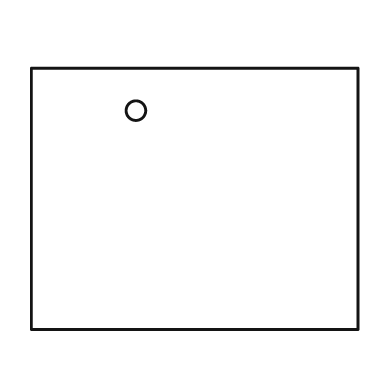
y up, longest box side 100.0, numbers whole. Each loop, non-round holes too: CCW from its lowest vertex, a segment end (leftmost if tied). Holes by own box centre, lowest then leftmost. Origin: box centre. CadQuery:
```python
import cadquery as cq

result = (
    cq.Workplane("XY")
    .moveTo(-50.0, -40.0)
    .lineTo(50.0, -40.0)
    .lineTo(50.0, 40.0)
    .lineTo(-50.0, 40.0)
    .close()
    .moveTo(-18.0, 27.0)
    .circle(3.0)
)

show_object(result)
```